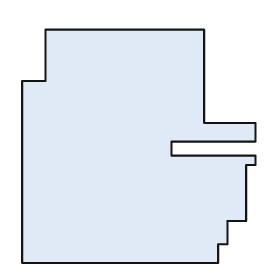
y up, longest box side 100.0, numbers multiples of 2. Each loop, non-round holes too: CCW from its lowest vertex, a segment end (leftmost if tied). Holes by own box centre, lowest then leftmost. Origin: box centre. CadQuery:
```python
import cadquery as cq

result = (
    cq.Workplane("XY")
    .moveTo(-50.0, -50.0)
    .lineTo(34.0, -50.0)
    .lineTo(34.0, -42.0)
    .lineTo(38.0, -42.0)
    .lineTo(38.0, -32.0)
    .lineTo(46.0, -32.0)
    .lineTo(46.0, -8.0)
    .lineTo(50.0, -8.0)
    .lineTo(50.0, -4.0)
    .lineTo(14.0, -4.0)
    .lineTo(14.0, 2.0)
    .lineTo(50.0, 2.0)
    .lineTo(50.0, 10.0)
    .lineTo(28.0, 10.0)
    .lineTo(28.0, 50.0)
    .lineTo(-40.0, 50.0)
    .lineTo(-40.0, 28.0)
    .lineTo(-50.0, 28.0)
    .close()
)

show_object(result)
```